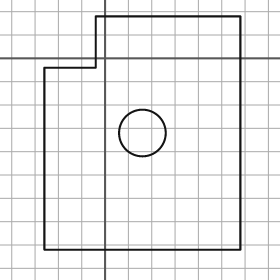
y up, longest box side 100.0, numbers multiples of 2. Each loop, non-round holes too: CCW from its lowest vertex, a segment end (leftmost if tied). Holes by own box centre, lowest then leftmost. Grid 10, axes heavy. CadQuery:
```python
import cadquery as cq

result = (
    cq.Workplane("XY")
    .moveTo(-26.0, -82.0)
    .lineTo(58.0, -82.0)
    .lineTo(58.0, 18.0)
    .lineTo(-4.0, 18.0)
    .lineTo(-4.0, -4.0)
    .lineTo(-26.0, -4.0)
    .close()
    .moveTo(16.0, -32.0)
    .circle(10.0)
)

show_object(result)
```